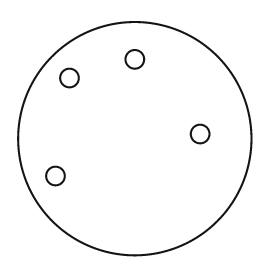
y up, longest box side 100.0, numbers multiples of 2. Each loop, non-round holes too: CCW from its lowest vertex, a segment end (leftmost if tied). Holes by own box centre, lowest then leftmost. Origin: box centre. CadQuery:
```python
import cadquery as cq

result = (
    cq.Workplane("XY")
    .moveTo(0.0, 0.0)
    .circle(50.0)
    .moveTo(-34.0, -16.0)
    .circle(4.0)
    .moveTo(28.0, 2.0)
    .circle(4.0)
    .moveTo(-28.0, 26.0)
    .circle(4.0)
    .moveTo(0.0, 34.0)
    .circle(4.0)
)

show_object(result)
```